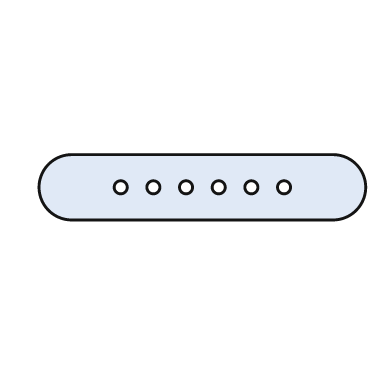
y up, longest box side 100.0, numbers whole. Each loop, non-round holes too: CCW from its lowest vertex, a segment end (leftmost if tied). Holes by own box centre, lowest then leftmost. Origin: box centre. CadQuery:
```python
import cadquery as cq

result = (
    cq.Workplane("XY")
    .moveTo(-40.0, -10.0)
    .lineTo(40.0, -10.0)
    .threePointArc((50.0, 0.0), (40.0, 10.0))
    .lineTo(-40.0, 10.0)
    .threePointArc((-50.0, 0.0), (-40.0, -10.0))
    .close()
    .moveTo(-25.0, 0.0)
    .circle(2.0)
    .moveTo(-15.0, 0.0)
    .circle(2.0)
    .moveTo(-5.0, 0.0)
    .circle(2.0)
    .moveTo(5.0, 0.0)
    .circle(2.0)
    .moveTo(15.0, 0.0)
    .circle(2.0)
    .moveTo(25.0, 0.0)
    .circle(2.0)
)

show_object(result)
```